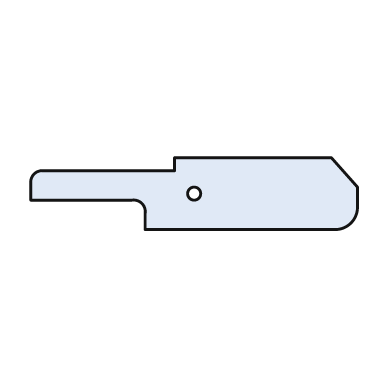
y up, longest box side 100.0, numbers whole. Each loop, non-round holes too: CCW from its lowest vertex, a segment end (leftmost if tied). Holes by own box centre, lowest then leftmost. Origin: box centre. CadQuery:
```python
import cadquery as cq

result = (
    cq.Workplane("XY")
    .moveTo(-15.0, -11.0)
    .lineTo(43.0, -11.0)
    .threePointArc((48.0, -9.0), (50.0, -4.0))
    .lineTo(50.0, 2.0)
    .lineTo(42.0, 11.0)
    .lineTo(-6.0, 11.0)
    .lineTo(-6.0, 7.0)
    .lineTo(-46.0, 7.0)
    .threePointArc((-49.0, 6.0), (-50.0, 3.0))
    .lineTo(-50.0, -2.0)
    .lineTo(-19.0, -2.0)
    .threePointArc((-16.0, -3.0), (-15.0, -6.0))
    .close()
    .moveTo(0.0, 0.0)
    .circle(2.0)
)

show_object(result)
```